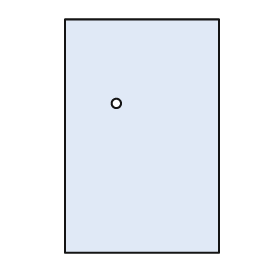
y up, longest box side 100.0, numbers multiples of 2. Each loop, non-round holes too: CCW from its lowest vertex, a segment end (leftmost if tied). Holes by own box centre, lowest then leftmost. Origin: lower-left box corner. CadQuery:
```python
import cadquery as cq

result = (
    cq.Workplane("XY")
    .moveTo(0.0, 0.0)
    .lineTo(66.0, 0.0)
    .lineTo(66.0, 100.0)
    .lineTo(0.0, 100.0)
    .close()
    .moveTo(22.0, 64.0)
    .circle(2.0)
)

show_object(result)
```